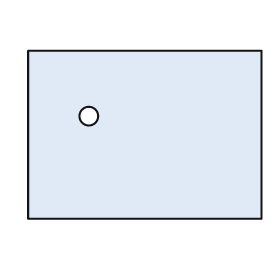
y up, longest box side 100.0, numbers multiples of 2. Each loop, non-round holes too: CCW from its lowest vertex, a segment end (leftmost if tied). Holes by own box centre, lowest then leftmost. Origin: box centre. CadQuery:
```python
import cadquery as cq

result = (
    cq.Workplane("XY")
    .moveTo(-50.0, -36.0)
    .lineTo(50.0, -36.0)
    .lineTo(50.0, 36.0)
    .lineTo(-50.0, 36.0)
    .close()
    .moveTo(-24.0, 8.0)
    .circle(4.0)
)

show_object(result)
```